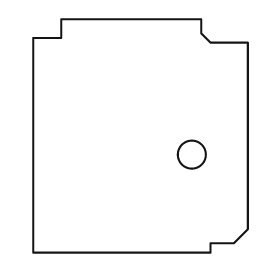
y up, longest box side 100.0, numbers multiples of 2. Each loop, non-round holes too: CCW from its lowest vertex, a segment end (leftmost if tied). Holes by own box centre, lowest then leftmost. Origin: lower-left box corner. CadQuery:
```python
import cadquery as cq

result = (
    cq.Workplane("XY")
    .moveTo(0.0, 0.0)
    .lineTo(76.0, 0.0)
    .lineTo(76.0, 4.0)
    .lineTo(86.0, 4.0)
    .lineTo(92.0, 10.0)
    .lineTo(92.0, 90.0)
    .lineTo(76.0, 90.0)
    .lineTo(72.0, 94.0)
    .lineTo(72.0, 100.0)
    .lineTo(12.0, 100.0)
    .lineTo(12.0, 92.0)
    .lineTo(0.0, 92.0)
    .close()
    .moveTo(68.0, 42.0)
    .circle(6.0)
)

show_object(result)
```